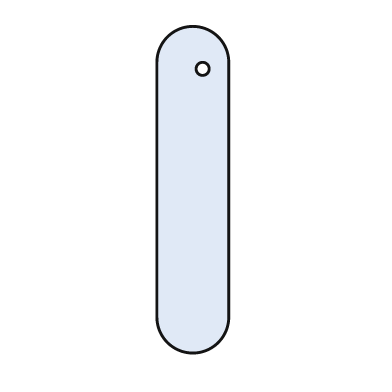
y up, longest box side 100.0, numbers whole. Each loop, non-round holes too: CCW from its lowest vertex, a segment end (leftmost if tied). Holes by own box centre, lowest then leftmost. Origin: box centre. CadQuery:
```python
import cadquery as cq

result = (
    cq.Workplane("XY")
    .moveTo(-11.0, -39.0)
    .threePointArc((0.0, -50.0), (11.0, -39.0))
    .lineTo(11.0, 39.0)
    .threePointArc((0.0, 50.0), (-11.0, 39.0))
    .close()
    .moveTo(3.0, 37.0)
    .circle(2.0)
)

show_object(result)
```